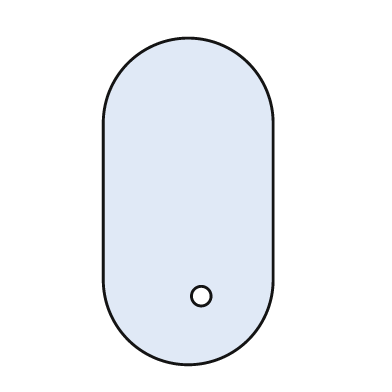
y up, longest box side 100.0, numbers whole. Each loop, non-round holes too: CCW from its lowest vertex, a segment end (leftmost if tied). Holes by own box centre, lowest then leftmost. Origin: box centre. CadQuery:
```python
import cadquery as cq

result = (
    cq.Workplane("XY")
    .moveTo(-26.0, -24.0)
    .threePointArc((0.0, -50.0), (26.0, -24.0))
    .lineTo(26.0, 24.0)
    .threePointArc((0.0, 50.0), (-26.0, 24.0))
    .close()
    .moveTo(4.0, -29.0)
    .circle(3.0)
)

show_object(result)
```